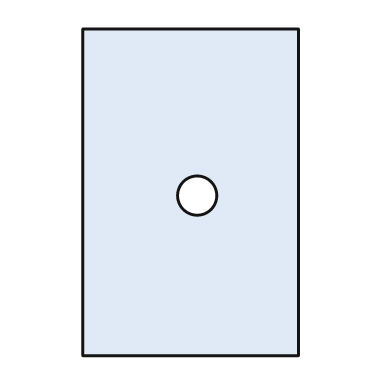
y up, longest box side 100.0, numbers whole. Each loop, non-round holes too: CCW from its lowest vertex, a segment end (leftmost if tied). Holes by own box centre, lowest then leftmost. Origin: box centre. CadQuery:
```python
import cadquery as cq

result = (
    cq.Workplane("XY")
    .moveTo(-33.0, -50.0)
    .lineTo(33.0, -50.0)
    .lineTo(33.0, 50.0)
    .lineTo(-33.0, 50.0)
    .close()
    .moveTo(2.0, -1.0)
    .circle(6.0)
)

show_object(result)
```